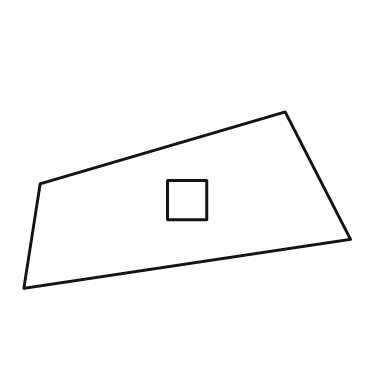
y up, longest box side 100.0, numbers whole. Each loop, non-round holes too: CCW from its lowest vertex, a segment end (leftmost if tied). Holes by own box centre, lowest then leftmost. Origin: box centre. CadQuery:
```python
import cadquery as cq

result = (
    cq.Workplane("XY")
    .moveTo(-50.0, -27.0)
    .lineTo(50.0, -12.0)
    .lineTo(30.0, 27.0)
    .lineTo(-45.0, 5.0)
    .close()
    .moveTo(-6.0, -6.0)
    .lineTo(6.0, -6.0)
    .lineTo(6.0, 6.0)
    .lineTo(-6.0, 6.0)
    .close()
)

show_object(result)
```